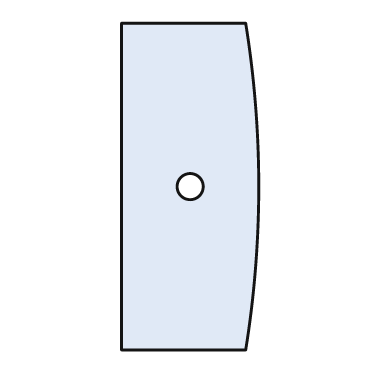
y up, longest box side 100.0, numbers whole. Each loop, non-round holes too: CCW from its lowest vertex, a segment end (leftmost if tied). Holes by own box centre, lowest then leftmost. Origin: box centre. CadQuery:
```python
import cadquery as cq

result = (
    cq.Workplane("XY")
    .moveTo(-21.0, -50.0)
    .lineTo(17.0, -50.0)
    .threePointArc((21.0, 0.0), (17.0, 50.0))
    .lineTo(-21.0, 50.0)
    .close()
    .moveTo(0.0, 0.0)
    .circle(4.0)
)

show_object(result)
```